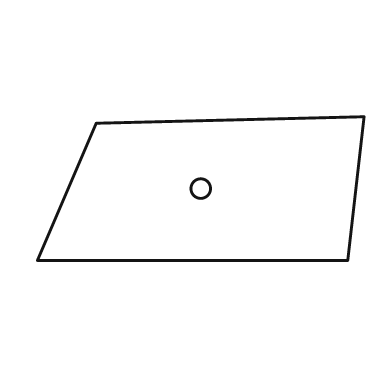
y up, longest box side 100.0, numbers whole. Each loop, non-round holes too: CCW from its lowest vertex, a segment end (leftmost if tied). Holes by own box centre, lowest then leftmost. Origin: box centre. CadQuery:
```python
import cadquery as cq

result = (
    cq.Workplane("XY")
    .moveTo(-50.0, -22.0)
    .lineTo(45.0, -22.0)
    .lineTo(50.0, 22.0)
    .lineTo(-32.0, 20.0)
    .close()
    .moveTo(0.0, 0.0)
    .circle(3.0)
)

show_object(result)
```